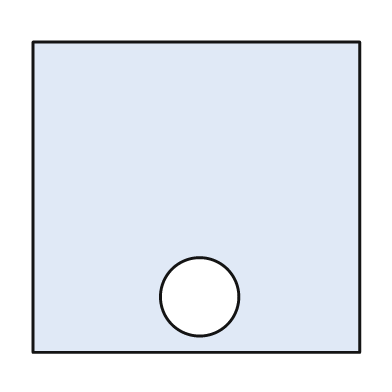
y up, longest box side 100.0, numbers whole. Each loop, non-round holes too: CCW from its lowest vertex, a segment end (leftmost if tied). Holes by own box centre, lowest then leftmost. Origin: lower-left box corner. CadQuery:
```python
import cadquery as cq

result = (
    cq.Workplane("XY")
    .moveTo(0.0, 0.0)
    .lineTo(100.0, 0.0)
    .lineTo(100.0, 95.0)
    .lineTo(0.0, 95.0)
    .close()
    .moveTo(51.0, 17.0)
    .circle(12.0)
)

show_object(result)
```